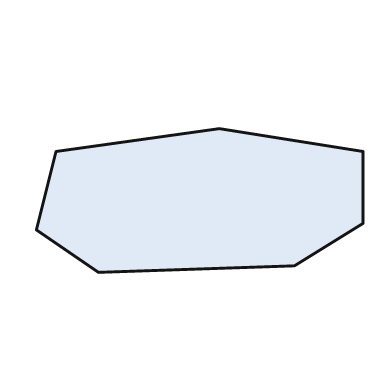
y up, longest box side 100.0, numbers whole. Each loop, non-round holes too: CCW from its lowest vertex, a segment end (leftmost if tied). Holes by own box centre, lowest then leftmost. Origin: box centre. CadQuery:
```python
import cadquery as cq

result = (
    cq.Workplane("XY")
    .moveTo(-31.0, -22.0)
    .lineTo(29.0, -20.0)
    .lineTo(50.0, -7.0)
    .lineTo(50.0, 15.0)
    .lineTo(6.0, 22.0)
    .lineTo(-44.0, 15.0)
    .lineTo(-50.0, -9.0)
    .close()
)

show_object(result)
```